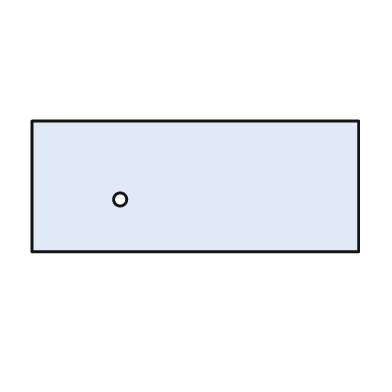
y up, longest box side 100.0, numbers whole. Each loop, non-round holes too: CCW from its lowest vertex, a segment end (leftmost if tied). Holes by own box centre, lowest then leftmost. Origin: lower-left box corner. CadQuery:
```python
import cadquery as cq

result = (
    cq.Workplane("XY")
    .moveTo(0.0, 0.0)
    .lineTo(100.0, 0.0)
    .lineTo(100.0, 40.0)
    .lineTo(0.0, 40.0)
    .close()
    .moveTo(27.0, 16.0)
    .circle(2.0)
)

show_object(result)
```